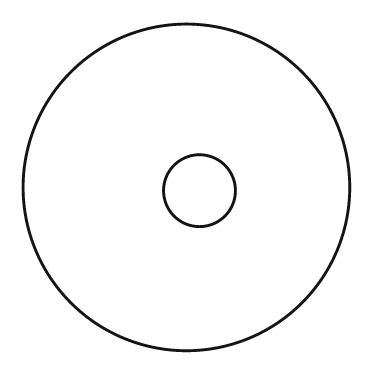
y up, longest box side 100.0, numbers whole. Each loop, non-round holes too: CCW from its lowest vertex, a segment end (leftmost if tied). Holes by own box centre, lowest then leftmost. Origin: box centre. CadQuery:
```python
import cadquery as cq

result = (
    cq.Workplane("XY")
    .moveTo(0.0, 0.0)
    .circle(50.0)
    .moveTo(4.0, -1.0)
    .circle(11.0)
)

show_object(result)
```